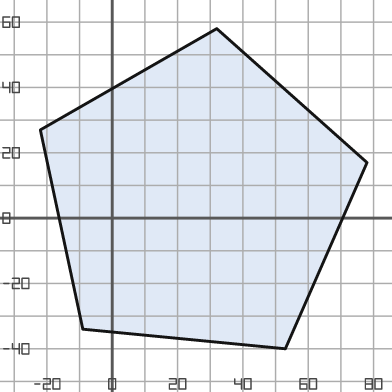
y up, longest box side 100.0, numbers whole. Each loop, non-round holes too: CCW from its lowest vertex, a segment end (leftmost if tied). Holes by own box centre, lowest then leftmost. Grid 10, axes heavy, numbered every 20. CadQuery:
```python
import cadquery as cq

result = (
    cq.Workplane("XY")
    .moveTo(53.0, -40.0)
    .lineTo(78.0, 17.0)
    .lineTo(32.0, 58.0)
    .lineTo(-22.0, 27.0)
    .lineTo(-9.0, -34.0)
    .close()
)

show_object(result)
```